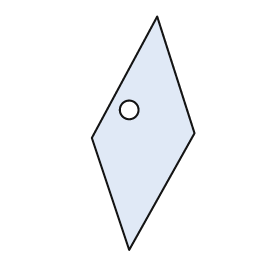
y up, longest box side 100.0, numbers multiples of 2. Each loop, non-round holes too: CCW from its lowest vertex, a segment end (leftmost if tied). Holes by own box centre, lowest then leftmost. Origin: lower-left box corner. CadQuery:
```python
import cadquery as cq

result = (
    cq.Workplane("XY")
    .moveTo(16.0, 0.0)
    .lineTo(44.0, 50.0)
    .lineTo(28.0, 100.0)
    .lineTo(0.0, 48.0)
    .close()
    .moveTo(16.0, 60.0)
    .circle(4.0)
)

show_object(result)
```